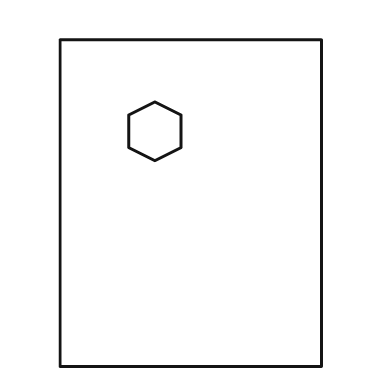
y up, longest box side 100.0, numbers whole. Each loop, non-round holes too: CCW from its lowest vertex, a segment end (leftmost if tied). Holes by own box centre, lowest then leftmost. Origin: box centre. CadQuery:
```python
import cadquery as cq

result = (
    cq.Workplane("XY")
    .moveTo(-40.0, -50.0)
    .lineTo(40.0, -50.0)
    .lineTo(40.0, 50.0)
    .lineTo(-40.0, 50.0)
    .close()
    .moveTo(-11.0, 13.0)
    .lineTo(-3.0, 17.0)
    .lineTo(-3.0, 27.0)
    .lineTo(-11.0, 31.0)
    .lineTo(-19.0, 27.0)
    .lineTo(-19.0, 17.0)
    .close()
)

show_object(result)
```